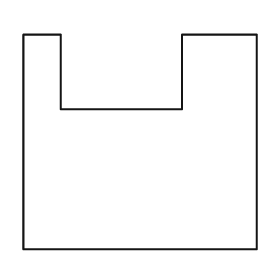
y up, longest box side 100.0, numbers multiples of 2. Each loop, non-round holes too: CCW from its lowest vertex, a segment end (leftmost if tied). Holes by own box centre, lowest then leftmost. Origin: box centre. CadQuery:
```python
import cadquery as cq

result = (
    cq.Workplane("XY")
    .moveTo(-50.0, -46.0)
    .lineTo(50.0, -46.0)
    .lineTo(50.0, 46.0)
    .lineTo(18.0, 46.0)
    .lineTo(18.0, 14.0)
    .lineTo(-34.0, 14.0)
    .lineTo(-34.0, 46.0)
    .lineTo(-50.0, 46.0)
    .close()
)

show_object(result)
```